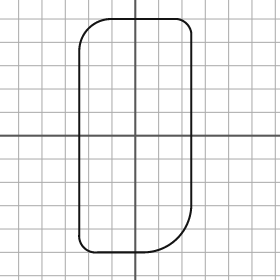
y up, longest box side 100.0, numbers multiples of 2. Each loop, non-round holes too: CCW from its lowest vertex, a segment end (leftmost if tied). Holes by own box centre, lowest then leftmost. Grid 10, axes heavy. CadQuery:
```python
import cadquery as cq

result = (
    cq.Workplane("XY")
    .moveTo(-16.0, -50.0)
    .lineTo(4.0, -50.0)
    .threePointArc((18.0, -44.0), (24.0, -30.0))
    .lineTo(24.0, 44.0)
    .threePointArc((22.0, 48.0), (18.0, 50.0))
    .lineTo(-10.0, 50.0)
    .threePointArc((-20.0, 46.0), (-24.0, 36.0))
    .lineTo(-24.0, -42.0)
    .threePointArc((-22.0, -48.0), (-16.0, -50.0))
    .close()
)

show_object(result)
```